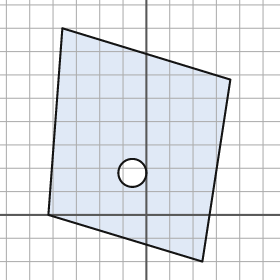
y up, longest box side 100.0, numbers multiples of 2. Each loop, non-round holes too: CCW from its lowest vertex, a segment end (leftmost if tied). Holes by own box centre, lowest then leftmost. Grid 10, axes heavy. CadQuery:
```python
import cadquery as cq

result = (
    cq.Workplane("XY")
    .moveTo(24.0, -20.0)
    .lineTo(36.0, 58.0)
    .lineTo(-36.0, 80.0)
    .lineTo(-42.0, 0.0)
    .close()
    .moveTo(-6.0, 18.0)
    .circle(6.0)
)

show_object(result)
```